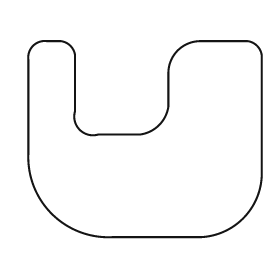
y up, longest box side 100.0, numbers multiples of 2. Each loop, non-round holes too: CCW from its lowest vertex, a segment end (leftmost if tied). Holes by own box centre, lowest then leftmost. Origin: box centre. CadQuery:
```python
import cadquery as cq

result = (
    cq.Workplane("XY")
    .moveTo(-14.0, -42.0)
    .lineTo(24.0, -42.0)
    .threePointArc((42.0, -34.0), (50.0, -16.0))
    .lineTo(50.0, 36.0)
    .threePointArc((48.0, 40.0), (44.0, 42.0))
    .lineTo(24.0, 42.0)
    .threePointArc((14.0, 38.0), (10.0, 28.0))
    .lineTo(10.0, 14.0)
    .threePointArc((6.0, 6.0), (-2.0, 2.0))
    .lineTo(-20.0, 2.0)
    .threePointArc((-28.0, 4.0), (-30.0, 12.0))
    .lineTo(-30.0, 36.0)
    .threePointArc((-32.0, 40.0), (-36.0, 42.0))
    .lineTo(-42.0, 42.0)
    .threePointArc((-48.0, 40.0), (-50.0, 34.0))
    .lineTo(-50.0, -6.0)
    .threePointArc((-40.0, -32.0), (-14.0, -42.0))
    .close()
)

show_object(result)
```